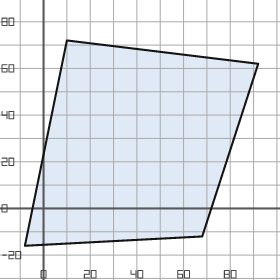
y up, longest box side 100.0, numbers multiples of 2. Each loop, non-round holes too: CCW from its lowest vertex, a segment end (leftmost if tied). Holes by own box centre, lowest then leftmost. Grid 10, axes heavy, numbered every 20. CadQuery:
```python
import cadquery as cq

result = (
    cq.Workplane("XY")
    .moveTo(-8.0, -16.0)
    .lineTo(68.0, -12.0)
    .lineTo(92.0, 62.0)
    .lineTo(10.0, 72.0)
    .close()
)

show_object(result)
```